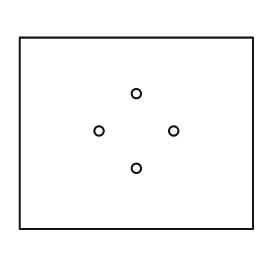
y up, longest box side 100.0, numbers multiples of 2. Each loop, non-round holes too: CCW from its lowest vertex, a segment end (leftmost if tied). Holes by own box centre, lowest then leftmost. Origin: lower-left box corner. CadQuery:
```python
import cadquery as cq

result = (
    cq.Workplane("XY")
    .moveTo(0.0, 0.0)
    .lineTo(100.0, 0.0)
    .lineTo(100.0, 82.0)
    .lineTo(0.0, 82.0)
    .close()
    .moveTo(50.0, 26.0)
    .circle(2.0)
    .moveTo(34.0, 42.0)
    .circle(2.0)
    .moveTo(66.0, 42.0)
    .circle(2.0)
    .moveTo(50.0, 58.0)
    .circle(2.0)
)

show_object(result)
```